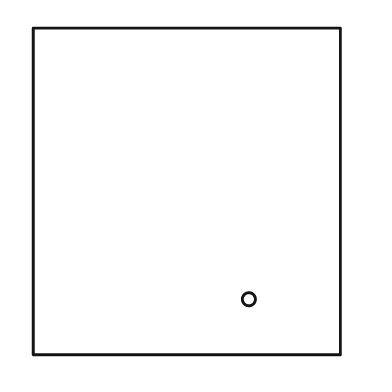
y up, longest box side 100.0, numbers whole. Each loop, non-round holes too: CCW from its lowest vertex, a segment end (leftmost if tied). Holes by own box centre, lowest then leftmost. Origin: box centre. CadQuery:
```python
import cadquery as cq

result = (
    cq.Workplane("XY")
    .moveTo(-47.0, -50.0)
    .lineTo(47.0, -50.0)
    .lineTo(47.0, 50.0)
    .lineTo(-47.0, 50.0)
    .close()
    .moveTo(19.0, -33.0)
    .circle(2.0)
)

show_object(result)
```